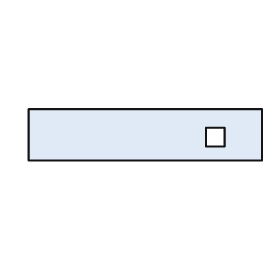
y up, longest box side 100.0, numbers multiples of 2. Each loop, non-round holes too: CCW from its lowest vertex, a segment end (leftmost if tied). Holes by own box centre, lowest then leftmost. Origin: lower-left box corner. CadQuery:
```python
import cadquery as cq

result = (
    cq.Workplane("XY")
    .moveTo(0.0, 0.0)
    .lineTo(100.0, 0.0)
    .lineTo(100.0, 22.0)
    .lineTo(0.0, 22.0)
    .close()
    .moveTo(76.0, 6.0)
    .lineTo(84.0, 6.0)
    .lineTo(84.0, 14.0)
    .lineTo(76.0, 14.0)
    .close()
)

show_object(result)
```